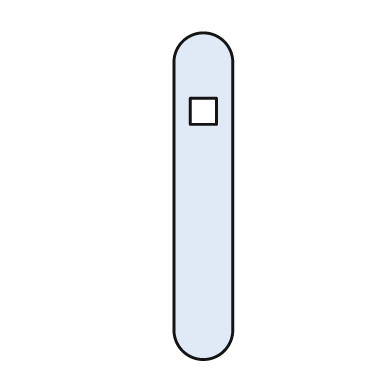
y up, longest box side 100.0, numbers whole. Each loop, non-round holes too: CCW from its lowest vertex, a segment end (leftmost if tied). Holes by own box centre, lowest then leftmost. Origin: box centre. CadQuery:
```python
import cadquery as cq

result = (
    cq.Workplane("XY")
    .moveTo(-9.0, -41.0)
    .threePointArc((0.0, -50.0), (9.0, -41.0))
    .lineTo(9.0, 41.0)
    .threePointArc((0.0, 50.0), (-9.0, 41.0))
    .close()
    .moveTo(-4.0, 22.0)
    .lineTo(4.0, 22.0)
    .lineTo(4.0, 30.0)
    .lineTo(-4.0, 30.0)
    .close()
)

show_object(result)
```